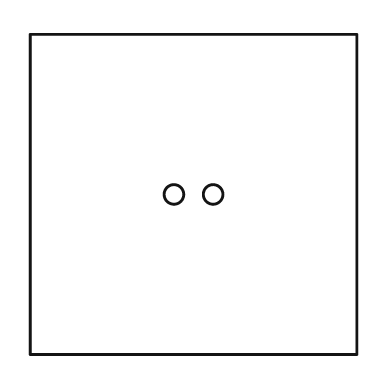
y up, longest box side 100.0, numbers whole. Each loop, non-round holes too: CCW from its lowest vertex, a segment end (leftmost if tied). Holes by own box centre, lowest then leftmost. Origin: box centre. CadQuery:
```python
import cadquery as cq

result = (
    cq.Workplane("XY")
    .moveTo(-50.0, -49.0)
    .lineTo(50.0, -49.0)
    .lineTo(50.0, 49.0)
    .lineTo(-50.0, 49.0)
    .close()
    .moveTo(-6.0, 0.0)
    .circle(3.0)
    .moveTo(6.0, 0.0)
    .circle(3.0)
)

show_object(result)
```